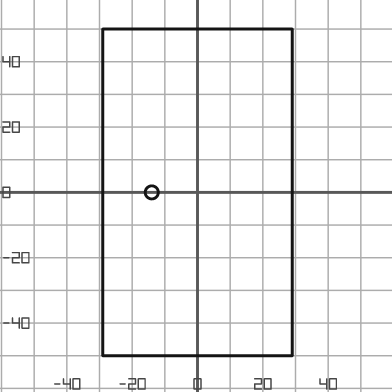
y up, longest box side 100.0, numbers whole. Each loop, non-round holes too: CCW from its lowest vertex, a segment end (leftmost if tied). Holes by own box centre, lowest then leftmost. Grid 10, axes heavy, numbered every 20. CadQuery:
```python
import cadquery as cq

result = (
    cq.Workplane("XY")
    .moveTo(-29.0, -50.0)
    .lineTo(29.0, -50.0)
    .lineTo(29.0, 50.0)
    .lineTo(-29.0, 50.0)
    .close()
    .moveTo(-14.0, 0.0)
    .circle(2.0)
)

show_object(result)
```